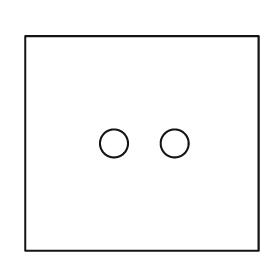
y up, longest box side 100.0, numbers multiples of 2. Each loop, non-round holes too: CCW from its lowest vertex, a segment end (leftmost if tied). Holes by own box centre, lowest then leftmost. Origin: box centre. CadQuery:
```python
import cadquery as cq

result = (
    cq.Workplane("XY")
    .moveTo(-50.0, -46.0)
    .lineTo(50.0, -46.0)
    .lineTo(50.0, 46.0)
    .lineTo(-50.0, 46.0)
    .close()
    .moveTo(-12.0, 0.0)
    .circle(6.0)
    .moveTo(14.0, 0.0)
    .circle(6.0)
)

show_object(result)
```